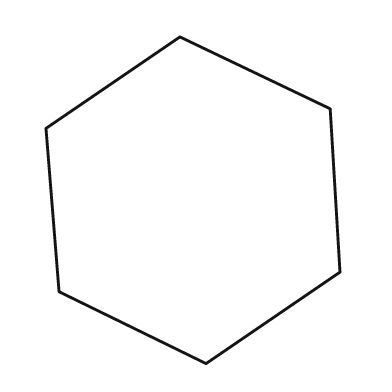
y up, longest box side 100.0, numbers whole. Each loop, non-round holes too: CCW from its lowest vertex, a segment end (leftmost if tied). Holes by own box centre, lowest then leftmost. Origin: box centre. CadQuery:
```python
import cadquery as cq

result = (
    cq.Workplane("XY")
    .moveTo(4.0, -50.0)
    .lineTo(45.0, -22.0)
    .lineTo(42.0, 28.0)
    .lineTo(-4.0, 50.0)
    .lineTo(-45.0, 22.0)
    .lineTo(-41.0, -28.0)
    .close()
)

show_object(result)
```